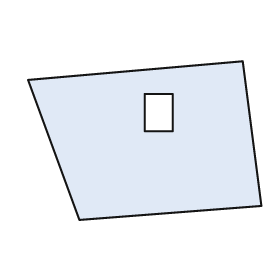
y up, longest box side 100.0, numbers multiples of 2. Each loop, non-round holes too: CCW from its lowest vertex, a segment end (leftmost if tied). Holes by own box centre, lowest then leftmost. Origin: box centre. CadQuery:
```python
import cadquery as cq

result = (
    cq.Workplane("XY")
    .moveTo(-28.0, -34.0)
    .lineTo(50.0, -28.0)
    .lineTo(42.0, 34.0)
    .lineTo(-50.0, 26.0)
    .close()
    .moveTo(0.0, 4.0)
    .lineTo(12.0, 4.0)
    .lineTo(12.0, 20.0)
    .lineTo(0.0, 20.0)
    .close()
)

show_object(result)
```